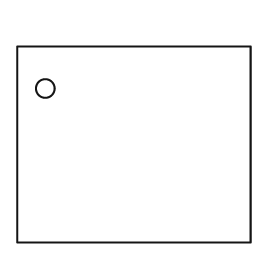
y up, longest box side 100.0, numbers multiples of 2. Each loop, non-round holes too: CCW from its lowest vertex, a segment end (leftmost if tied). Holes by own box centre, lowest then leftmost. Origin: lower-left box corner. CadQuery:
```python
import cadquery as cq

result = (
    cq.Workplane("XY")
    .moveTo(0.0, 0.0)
    .lineTo(100.0, 0.0)
    .lineTo(100.0, 84.0)
    .lineTo(0.0, 84.0)
    .close()
    .moveTo(12.0, 66.0)
    .circle(4.0)
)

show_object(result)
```